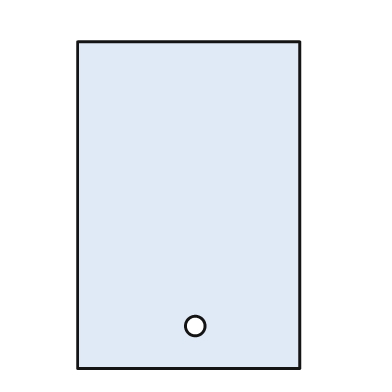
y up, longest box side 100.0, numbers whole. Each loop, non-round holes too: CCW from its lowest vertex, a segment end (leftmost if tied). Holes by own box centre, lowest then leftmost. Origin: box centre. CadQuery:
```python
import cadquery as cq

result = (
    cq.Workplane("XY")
    .moveTo(-34.0, -50.0)
    .lineTo(34.0, -50.0)
    .lineTo(34.0, 50.0)
    .lineTo(-34.0, 50.0)
    .close()
    .moveTo(2.0, -37.0)
    .circle(3.0)
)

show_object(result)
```